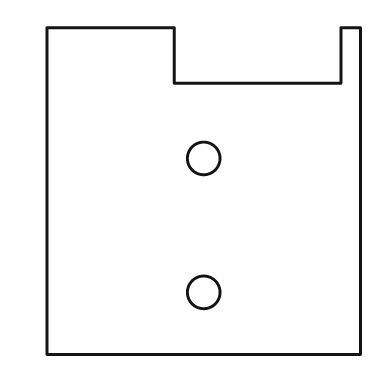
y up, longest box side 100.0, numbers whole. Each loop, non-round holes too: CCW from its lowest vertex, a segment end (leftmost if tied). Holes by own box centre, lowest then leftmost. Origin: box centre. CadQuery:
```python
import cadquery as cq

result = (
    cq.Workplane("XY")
    .moveTo(-48.0, -50.0)
    .lineTo(48.0, -50.0)
    .lineTo(48.0, 50.0)
    .lineTo(42.0, 50.0)
    .lineTo(42.0, 33.0)
    .lineTo(-9.0, 33.0)
    .lineTo(-9.0, 50.0)
    .lineTo(-48.0, 50.0)
    .close()
    .moveTo(0.0, -31.0)
    .circle(5.0)
    .moveTo(0.0, 10.0)
    .circle(5.0)
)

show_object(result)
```